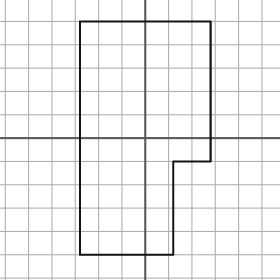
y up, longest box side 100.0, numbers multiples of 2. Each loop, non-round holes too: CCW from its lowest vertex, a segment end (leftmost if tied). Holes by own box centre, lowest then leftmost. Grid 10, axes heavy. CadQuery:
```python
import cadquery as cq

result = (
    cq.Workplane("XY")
    .moveTo(-28.0, -50.0)
    .lineTo(12.0, -50.0)
    .lineTo(12.0, -10.0)
    .lineTo(28.0, -10.0)
    .lineTo(28.0, 50.0)
    .lineTo(-28.0, 50.0)
    .close()
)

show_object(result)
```